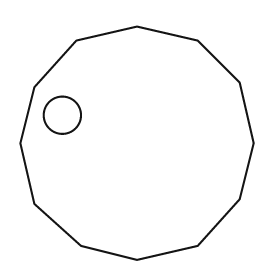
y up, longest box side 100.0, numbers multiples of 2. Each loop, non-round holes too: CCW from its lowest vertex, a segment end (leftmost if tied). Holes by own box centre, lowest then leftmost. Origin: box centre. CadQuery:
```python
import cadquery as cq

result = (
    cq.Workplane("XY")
    .moveTo(0.0, -50.0)
    .lineTo(26.0, -44.0)
    .lineTo(44.0, -24.0)
    .lineTo(50.0, 0.0)
    .lineTo(44.0, 26.0)
    .lineTo(26.0, 44.0)
    .lineTo(0.0, 50.0)
    .lineTo(-26.0, 44.0)
    .lineTo(-44.0, 24.0)
    .lineTo(-50.0, 0.0)
    .lineTo(-44.0, -26.0)
    .lineTo(-24.0, -44.0)
    .close()
    .moveTo(-32.0, 12.0)
    .circle(8.0)
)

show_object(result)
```